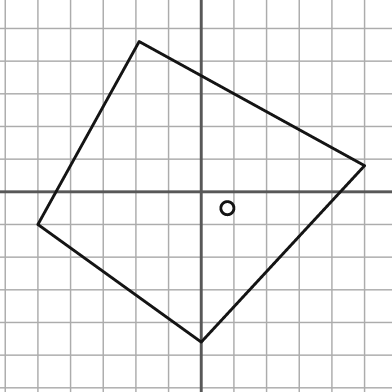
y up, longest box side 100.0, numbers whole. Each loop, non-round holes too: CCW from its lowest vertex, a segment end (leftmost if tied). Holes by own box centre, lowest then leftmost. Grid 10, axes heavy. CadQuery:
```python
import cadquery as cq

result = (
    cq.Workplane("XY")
    .moveTo(0.0, -46.0)
    .lineTo(50.0, 8.0)
    .lineTo(-19.0, 46.0)
    .lineTo(-50.0, -10.0)
    .close()
    .moveTo(8.0, -5.0)
    .circle(2.0)
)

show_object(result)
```